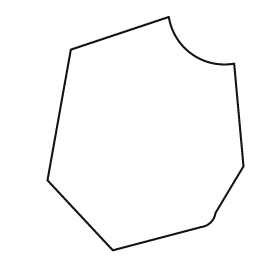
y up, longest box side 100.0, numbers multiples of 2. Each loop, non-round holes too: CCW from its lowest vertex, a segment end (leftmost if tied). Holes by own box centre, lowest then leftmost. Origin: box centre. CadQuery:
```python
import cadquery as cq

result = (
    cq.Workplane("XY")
    .moveTo(-14.0, -50.0)
    .lineTo(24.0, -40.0)
    .threePointArc((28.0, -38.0), (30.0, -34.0))
    .lineTo(42.0, -14.0)
    .lineTo(38.0, 30.0)
    .threePointArc((20.0, 34.0), (10.0, 50.0))
    .lineTo(-32.0, 36.0)
    .lineTo(-42.0, -20.0)
    .close()
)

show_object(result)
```